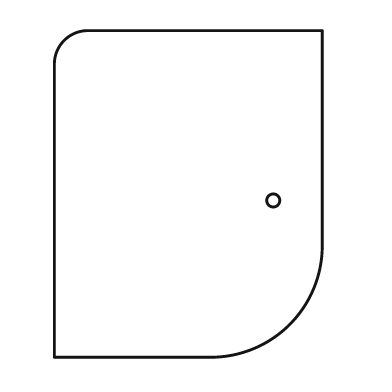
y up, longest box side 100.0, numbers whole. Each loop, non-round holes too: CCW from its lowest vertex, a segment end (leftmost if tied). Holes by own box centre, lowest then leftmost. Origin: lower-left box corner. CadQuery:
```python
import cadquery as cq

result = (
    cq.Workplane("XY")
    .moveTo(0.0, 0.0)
    .lineTo(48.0, 0.0)
    .threePointArc((72.0, 10.0), (82.0, 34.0))
    .lineTo(82.0, 100.0)
    .lineTo(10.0, 100.0)
    .threePointArc((3.0, 97.0), (0.0, 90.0))
    .close()
    .moveTo(67.0, 48.0)
    .circle(2.0)
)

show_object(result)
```